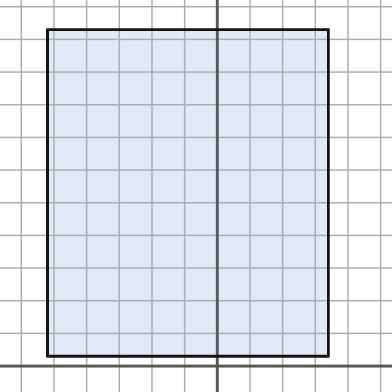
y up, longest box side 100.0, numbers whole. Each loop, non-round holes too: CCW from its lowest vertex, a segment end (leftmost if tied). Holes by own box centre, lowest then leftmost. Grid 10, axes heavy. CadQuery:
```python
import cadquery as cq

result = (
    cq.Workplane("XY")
    .moveTo(-52.0, 3.0)
    .lineTo(34.0, 3.0)
    .lineTo(34.0, 103.0)
    .lineTo(-52.0, 103.0)
    .close()
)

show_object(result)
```